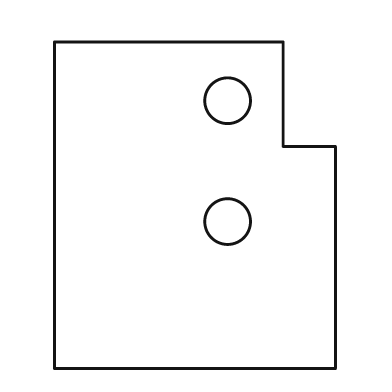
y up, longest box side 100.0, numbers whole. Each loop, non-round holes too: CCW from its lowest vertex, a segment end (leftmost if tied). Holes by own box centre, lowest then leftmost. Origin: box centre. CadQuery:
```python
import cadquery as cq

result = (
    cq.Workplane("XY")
    .moveTo(-43.0, -50.0)
    .lineTo(43.0, -50.0)
    .lineTo(43.0, 18.0)
    .lineTo(27.0, 18.0)
    .lineTo(27.0, 50.0)
    .lineTo(-43.0, 50.0)
    .close()
    .moveTo(10.0, -5.0)
    .circle(7.0)
    .moveTo(10.0, 32.0)
    .circle(7.0)
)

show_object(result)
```